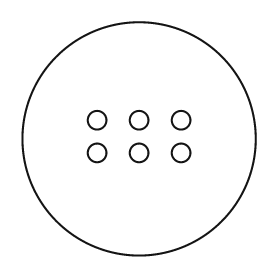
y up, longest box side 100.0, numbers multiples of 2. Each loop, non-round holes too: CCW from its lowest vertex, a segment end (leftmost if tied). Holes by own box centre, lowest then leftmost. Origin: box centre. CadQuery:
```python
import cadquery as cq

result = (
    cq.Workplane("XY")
    .moveTo(0.0, 0.0)
    .circle(50.0)
    .moveTo(-18.0, -6.0)
    .circle(4.0)
    .moveTo(0.0, -6.0)
    .circle(4.0)
    .moveTo(18.0, -6.0)
    .circle(4.0)
    .moveTo(-18.0, 8.0)
    .circle(4.0)
    .moveTo(0.0, 8.0)
    .circle(4.0)
    .moveTo(18.0, 8.0)
    .circle(4.0)
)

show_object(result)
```